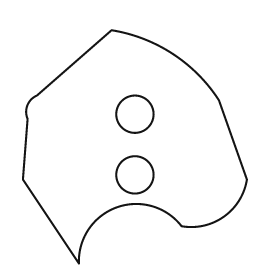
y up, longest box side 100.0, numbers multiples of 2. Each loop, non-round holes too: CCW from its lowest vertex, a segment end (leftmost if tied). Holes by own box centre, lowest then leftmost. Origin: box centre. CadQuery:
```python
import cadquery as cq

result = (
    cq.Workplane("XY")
    .moveTo(-24.0, -50.0)
    .threePointArc((-8.0, -26.0), (20.0, -34.0))
    .threePointArc((38.0, -30.0), (48.0, -14.0))
    .lineTo(36.0, 20.0)
    .threePointArc((16.0, 40.0), (-10.0, 50.0))
    .lineTo(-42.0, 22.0)
    .threePointArc((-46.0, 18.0), (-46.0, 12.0))
    .lineTo(-48.0, -14.0)
    .close()
    .moveTo(0.0, -12.0)
    .circle(8.0)
    .moveTo(0.0, 14.0)
    .circle(8.0)
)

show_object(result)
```